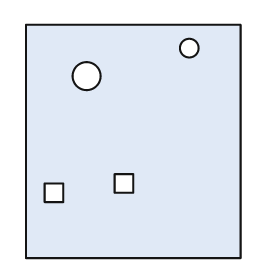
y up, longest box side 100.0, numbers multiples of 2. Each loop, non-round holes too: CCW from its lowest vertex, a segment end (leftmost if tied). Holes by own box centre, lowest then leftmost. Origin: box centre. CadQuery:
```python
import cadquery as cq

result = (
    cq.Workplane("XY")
    .moveTo(-46.0, -50.0)
    .lineTo(46.0, -50.0)
    .lineTo(46.0, 50.0)
    .lineTo(-46.0, 50.0)
    .close()
    .moveTo(-38.0, -26.0)
    .lineTo(-30.0, -26.0)
    .lineTo(-30.0, -18.0)
    .lineTo(-38.0, -18.0)
    .close()
    .moveTo(-8.0, -22.0)
    .lineTo(0.0, -22.0)
    .lineTo(0.0, -14.0)
    .lineTo(-8.0, -14.0)
    .close()
    .moveTo(-20.0, 28.0)
    .circle(6.0)
    .moveTo(24.0, 40.0)
    .circle(4.0)
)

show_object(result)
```